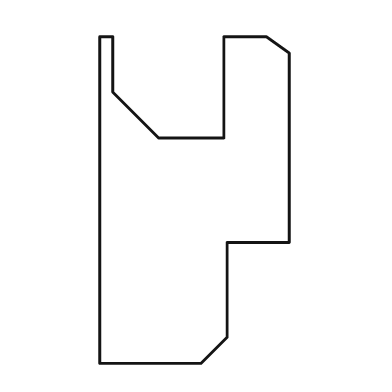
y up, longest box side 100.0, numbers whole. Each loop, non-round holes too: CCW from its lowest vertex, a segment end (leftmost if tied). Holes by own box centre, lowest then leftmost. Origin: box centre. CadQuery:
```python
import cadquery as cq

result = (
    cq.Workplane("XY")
    .moveTo(-29.0, -50.0)
    .lineTo(2.0, -50.0)
    .lineTo(10.0, -42.0)
    .lineTo(10.0, -13.0)
    .lineTo(29.0, -13.0)
    .lineTo(29.0, 45.0)
    .lineTo(22.0, 50.0)
    .lineTo(9.0, 50.0)
    .lineTo(9.0, 19.0)
    .lineTo(-11.0, 19.0)
    .lineTo(-25.0, 33.0)
    .lineTo(-25.0, 50.0)
    .lineTo(-29.0, 50.0)
    .close()
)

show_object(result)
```